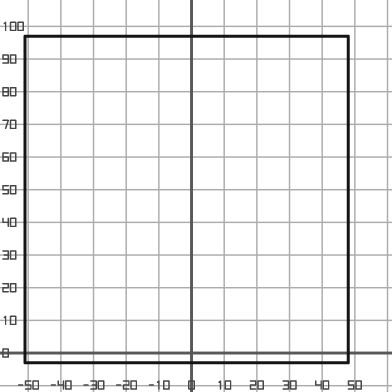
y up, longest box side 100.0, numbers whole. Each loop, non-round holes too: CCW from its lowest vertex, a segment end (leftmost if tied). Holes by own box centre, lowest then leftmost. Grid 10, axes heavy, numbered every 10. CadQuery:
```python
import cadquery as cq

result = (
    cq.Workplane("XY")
    .moveTo(-51.0, -3.0)
    .lineTo(48.0, -3.0)
    .lineTo(48.0, 97.0)
    .lineTo(-51.0, 97.0)
    .close()
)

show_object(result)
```